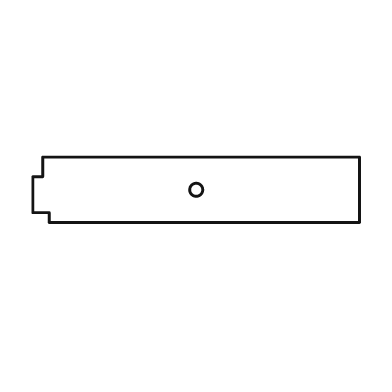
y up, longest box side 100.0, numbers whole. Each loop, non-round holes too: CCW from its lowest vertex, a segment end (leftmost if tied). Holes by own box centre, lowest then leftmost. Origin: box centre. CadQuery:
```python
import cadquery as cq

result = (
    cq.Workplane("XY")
    .moveTo(-45.0, -10.0)
    .lineTo(50.0, -10.0)
    .lineTo(50.0, 10.0)
    .lineTo(-47.0, 10.0)
    .lineTo(-47.0, 4.0)
    .lineTo(-50.0, 4.0)
    .lineTo(-50.0, -7.0)
    .lineTo(-45.0, -7.0)
    .close()
    .moveTo(0.0, 0.0)
    .circle(2.0)
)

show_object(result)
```